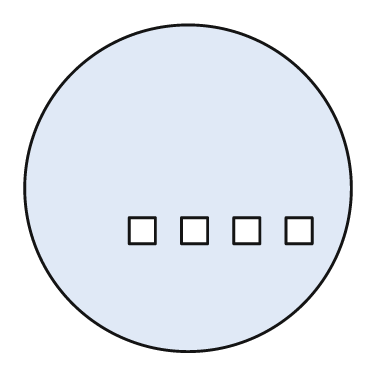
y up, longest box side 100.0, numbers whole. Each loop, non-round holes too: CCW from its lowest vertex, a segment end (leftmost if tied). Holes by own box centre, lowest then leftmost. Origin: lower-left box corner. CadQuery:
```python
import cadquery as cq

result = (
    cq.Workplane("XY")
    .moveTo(50.0, 50.0)
    .circle(50.0)
    .moveTo(32.0, 33.0)
    .lineTo(40.0, 33.0)
    .lineTo(40.0, 41.0)
    .lineTo(32.0, 41.0)
    .close()
    .moveTo(48.0, 33.0)
    .lineTo(56.0, 33.0)
    .lineTo(56.0, 41.0)
    .lineTo(48.0, 41.0)
    .close()
    .moveTo(64.0, 33.0)
    .lineTo(72.0, 33.0)
    .lineTo(72.0, 41.0)
    .lineTo(64.0, 41.0)
    .close()
    .moveTo(80.0, 33.0)
    .lineTo(88.0, 33.0)
    .lineTo(88.0, 41.0)
    .lineTo(80.0, 41.0)
    .close()
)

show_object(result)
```